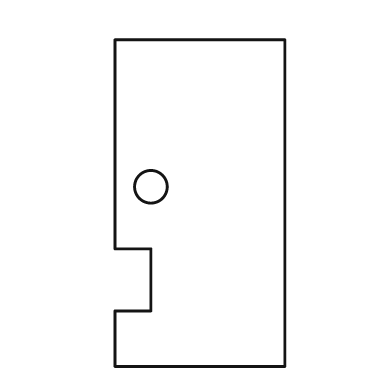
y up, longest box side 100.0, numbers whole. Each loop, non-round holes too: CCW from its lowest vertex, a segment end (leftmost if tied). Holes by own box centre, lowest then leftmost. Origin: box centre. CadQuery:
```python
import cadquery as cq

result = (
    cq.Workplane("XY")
    .moveTo(-26.0, -50.0)
    .lineTo(26.0, -50.0)
    .lineTo(26.0, 50.0)
    .lineTo(-26.0, 50.0)
    .lineTo(-26.0, -14.0)
    .lineTo(-15.0, -14.0)
    .lineTo(-15.0, -33.0)
    .lineTo(-26.0, -33.0)
    .close()
    .moveTo(-15.0, 5.0)
    .circle(5.0)
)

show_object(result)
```